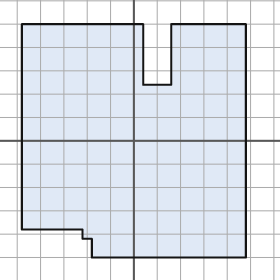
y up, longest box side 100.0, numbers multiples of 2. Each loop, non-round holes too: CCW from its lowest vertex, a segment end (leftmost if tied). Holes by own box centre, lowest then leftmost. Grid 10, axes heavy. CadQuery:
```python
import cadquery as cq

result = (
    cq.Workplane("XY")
    .moveTo(-18.0, -50.0)
    .lineTo(48.0, -50.0)
    .lineTo(48.0, 50.0)
    .lineTo(16.0, 50.0)
    .lineTo(16.0, 24.0)
    .lineTo(4.0, 24.0)
    .lineTo(4.0, 50.0)
    .lineTo(-48.0, 50.0)
    .lineTo(-48.0, -38.0)
    .lineTo(-22.0, -38.0)
    .lineTo(-22.0, -42.0)
    .lineTo(-18.0, -42.0)
    .close()
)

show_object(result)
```